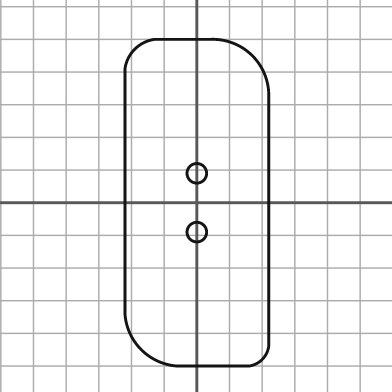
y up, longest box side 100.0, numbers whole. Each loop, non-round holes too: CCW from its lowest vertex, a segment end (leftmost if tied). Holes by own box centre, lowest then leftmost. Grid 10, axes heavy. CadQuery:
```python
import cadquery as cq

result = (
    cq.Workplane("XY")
    .moveTo(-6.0, -50.0)
    .lineTo(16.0, -50.0)
    .threePointArc((20.0, -48.0), (22.0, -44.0))
    .lineTo(22.0, 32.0)
    .threePointArc((17.0, 45.0), (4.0, 50.0))
    .lineTo(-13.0, 50.0)
    .threePointArc((-19.0, 47.0), (-22.0, 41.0))
    .lineTo(-22.0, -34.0)
    .threePointArc((-17.0, -45.0), (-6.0, -50.0))
    .close()
    .moveTo(0.0, -9.0)
    .circle(3.0)
    .moveTo(0.0, 9.0)
    .circle(3.0)
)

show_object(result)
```